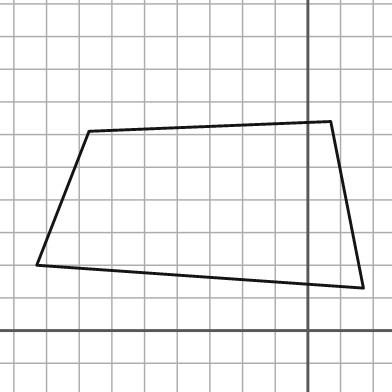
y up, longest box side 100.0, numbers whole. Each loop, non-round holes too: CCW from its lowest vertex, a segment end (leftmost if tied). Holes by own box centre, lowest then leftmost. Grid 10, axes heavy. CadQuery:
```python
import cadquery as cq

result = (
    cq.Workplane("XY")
    .moveTo(17.0, 13.0)
    .lineTo(7.0, 64.0)
    .lineTo(-67.0, 61.0)
    .lineTo(-83.0, 20.0)
    .close()
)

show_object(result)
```